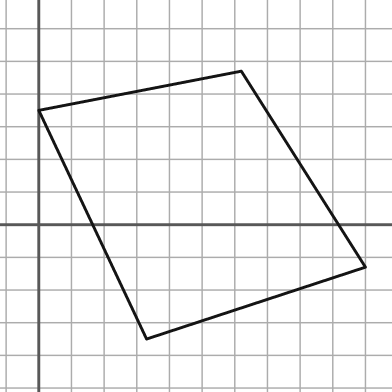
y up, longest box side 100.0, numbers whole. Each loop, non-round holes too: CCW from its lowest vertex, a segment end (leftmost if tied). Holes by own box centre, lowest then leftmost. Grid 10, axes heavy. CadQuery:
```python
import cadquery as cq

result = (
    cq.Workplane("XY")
    .moveTo(33.0, -35.0)
    .lineTo(100.0, -13.0)
    .lineTo(62.0, 47.0)
    .lineTo(0.0, 35.0)
    .close()
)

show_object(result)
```